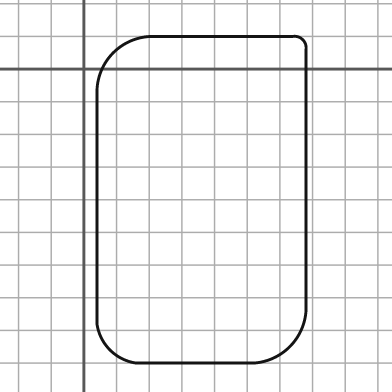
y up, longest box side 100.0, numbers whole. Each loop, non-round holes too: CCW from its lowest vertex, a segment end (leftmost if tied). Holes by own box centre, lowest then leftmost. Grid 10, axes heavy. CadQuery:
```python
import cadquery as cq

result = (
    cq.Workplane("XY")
    .moveTo(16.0, -90.0)
    .lineTo(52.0, -90.0)
    .threePointArc((63.0, -85.0), (68.0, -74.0))
    .lineTo(68.0, 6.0)
    .threePointArc((67.0, 9.0), (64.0, 10.0))
    .lineTo(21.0, 10.0)
    .threePointArc((9.0, 5.0), (4.0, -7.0))
    .lineTo(4.0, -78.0)
    .threePointArc((8.0, -86.0), (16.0, -90.0))
    .close()
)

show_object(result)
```